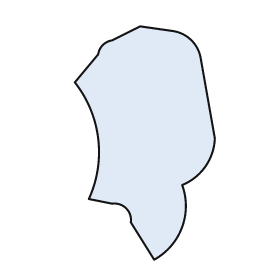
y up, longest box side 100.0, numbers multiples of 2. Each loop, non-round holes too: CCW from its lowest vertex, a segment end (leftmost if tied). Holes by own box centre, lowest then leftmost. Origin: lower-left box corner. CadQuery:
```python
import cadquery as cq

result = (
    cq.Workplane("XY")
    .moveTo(34.0, 0.0)
    .threePointArc((46.0, 14.0), (46.0, 32.0))
    .threePointArc((56.0, 40.0), (60.0, 52.0))
    .lineTo(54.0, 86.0)
    .threePointArc((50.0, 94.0), (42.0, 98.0))
    .lineTo(28.0, 100.0)
    .lineTo(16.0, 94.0)
    .threePointArc((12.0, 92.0), (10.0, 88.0))
    .lineTo(0.0, 76.0)
    .threePointArc((10.0, 52.0), (6.0, 26.0))
    .lineTo(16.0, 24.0)
    .threePointArc((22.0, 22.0), (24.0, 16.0))
    .close()
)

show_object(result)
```